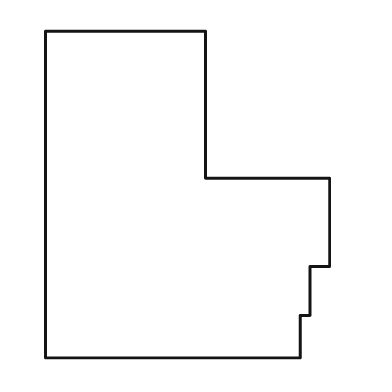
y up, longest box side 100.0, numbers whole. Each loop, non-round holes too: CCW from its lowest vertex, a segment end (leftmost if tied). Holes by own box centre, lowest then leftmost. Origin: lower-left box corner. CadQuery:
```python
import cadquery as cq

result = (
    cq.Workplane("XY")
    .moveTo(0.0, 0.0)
    .lineTo(78.0, 0.0)
    .lineTo(78.0, 13.0)
    .lineTo(81.0, 13.0)
    .lineTo(81.0, 28.0)
    .lineTo(87.0, 28.0)
    .lineTo(87.0, 55.0)
    .lineTo(49.0, 55.0)
    .lineTo(49.0, 100.0)
    .lineTo(0.0, 100.0)
    .close()
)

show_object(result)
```